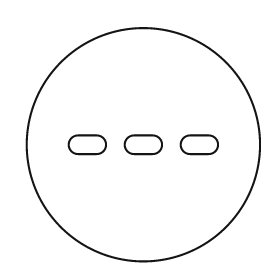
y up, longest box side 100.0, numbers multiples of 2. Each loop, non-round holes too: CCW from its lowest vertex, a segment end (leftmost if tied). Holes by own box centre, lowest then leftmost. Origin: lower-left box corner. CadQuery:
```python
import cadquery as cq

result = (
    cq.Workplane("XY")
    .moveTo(50.0, 50.0)
    .circle(50.0)
    .moveTo(22.0, 46.0)
    .lineTo(30.0, 46.0)
    .threePointArc((34.0, 50.0), (30.0, 54.0))
    .lineTo(22.0, 54.0)
    .threePointArc((18.0, 50.0), (22.0, 46.0))
    .close()
    .moveTo(46.0, 46.0)
    .lineTo(54.0, 46.0)
    .threePointArc((58.0, 50.0), (54.0, 54.0))
    .lineTo(46.0, 54.0)
    .threePointArc((42.0, 50.0), (46.0, 46.0))
    .close()
    .moveTo(70.0, 46.0)
    .lineTo(78.0, 46.0)
    .threePointArc((82.0, 50.0), (78.0, 54.0))
    .lineTo(70.0, 54.0)
    .threePointArc((66.0, 50.0), (70.0, 46.0))
    .close()
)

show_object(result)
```